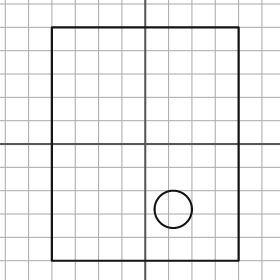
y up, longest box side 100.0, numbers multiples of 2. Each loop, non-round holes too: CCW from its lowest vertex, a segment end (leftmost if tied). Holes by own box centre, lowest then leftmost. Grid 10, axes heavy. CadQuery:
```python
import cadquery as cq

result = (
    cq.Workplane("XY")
    .moveTo(-40.0, -50.0)
    .lineTo(40.0, -50.0)
    .lineTo(40.0, 50.0)
    .lineTo(-40.0, 50.0)
    .close()
    .moveTo(12.0, -28.0)
    .circle(8.0)
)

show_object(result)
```